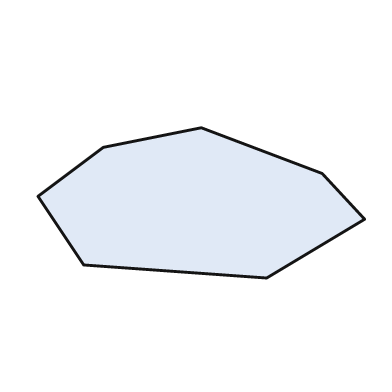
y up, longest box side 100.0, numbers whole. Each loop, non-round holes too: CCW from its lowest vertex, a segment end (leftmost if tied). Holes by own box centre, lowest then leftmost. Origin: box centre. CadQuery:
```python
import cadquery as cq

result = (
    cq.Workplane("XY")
    .moveTo(20.0, -23.0)
    .lineTo(50.0, -5.0)
    .lineTo(37.0, 9.0)
    .lineTo(0.0, 23.0)
    .lineTo(-30.0, 17.0)
    .lineTo(-50.0, 2.0)
    .lineTo(-36.0, -19.0)
    .close()
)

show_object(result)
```